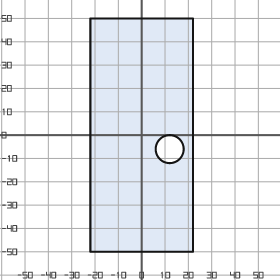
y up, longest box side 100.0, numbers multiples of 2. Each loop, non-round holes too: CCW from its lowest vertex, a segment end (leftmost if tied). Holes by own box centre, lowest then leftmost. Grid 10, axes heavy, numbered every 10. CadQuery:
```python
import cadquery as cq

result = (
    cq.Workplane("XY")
    .moveTo(-22.0, -50.0)
    .lineTo(22.0, -50.0)
    .lineTo(22.0, 50.0)
    .lineTo(-22.0, 50.0)
    .close()
    .moveTo(12.0, -6.0)
    .circle(6.0)
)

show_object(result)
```